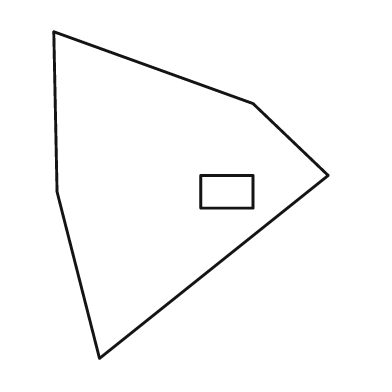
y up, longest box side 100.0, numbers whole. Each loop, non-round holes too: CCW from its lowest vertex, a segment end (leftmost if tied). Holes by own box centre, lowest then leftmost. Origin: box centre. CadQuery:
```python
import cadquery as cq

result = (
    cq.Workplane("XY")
    .moveTo(-28.0, -50.0)
    .lineTo(42.0, 6.0)
    .lineTo(19.0, 28.0)
    .lineTo(-42.0, 50.0)
    .lineTo(-41.0, 1.0)
    .close()
    .moveTo(3.0, -4.0)
    .lineTo(19.0, -4.0)
    .lineTo(19.0, 6.0)
    .lineTo(3.0, 6.0)
    .close()
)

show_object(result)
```